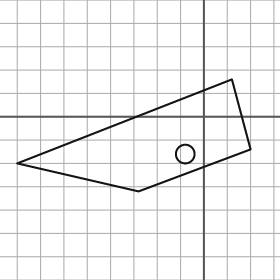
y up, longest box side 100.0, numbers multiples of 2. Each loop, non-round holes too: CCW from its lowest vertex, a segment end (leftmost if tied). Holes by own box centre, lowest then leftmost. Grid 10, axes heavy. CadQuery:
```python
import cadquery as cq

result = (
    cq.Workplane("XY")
    .moveTo(-28.0, -32.0)
    .lineTo(20.0, -14.0)
    .lineTo(12.0, 16.0)
    .lineTo(-80.0, -20.0)
    .close()
    .moveTo(-8.0, -16.0)
    .circle(4.0)
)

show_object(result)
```